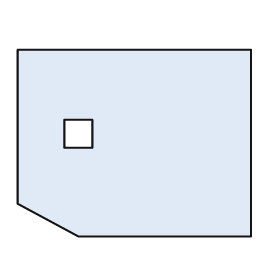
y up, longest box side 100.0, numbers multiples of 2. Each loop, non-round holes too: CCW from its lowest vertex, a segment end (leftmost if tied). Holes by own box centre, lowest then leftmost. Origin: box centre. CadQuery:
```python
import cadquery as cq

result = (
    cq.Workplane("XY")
    .moveTo(-24.0, -40.0)
    .lineTo(50.0, -40.0)
    .lineTo(50.0, 40.0)
    .lineTo(-50.0, 40.0)
    .lineTo(-50.0, -26.0)
    .close()
    .moveTo(-30.0, -2.0)
    .lineTo(-18.0, -2.0)
    .lineTo(-18.0, 10.0)
    .lineTo(-30.0, 10.0)
    .close()
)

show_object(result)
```